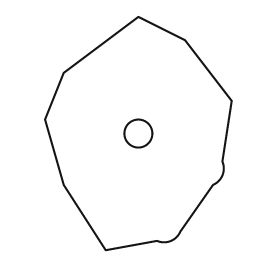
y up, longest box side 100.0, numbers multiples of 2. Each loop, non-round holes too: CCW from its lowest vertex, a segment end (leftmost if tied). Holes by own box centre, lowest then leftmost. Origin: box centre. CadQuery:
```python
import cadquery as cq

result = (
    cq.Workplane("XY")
    .moveTo(-14.0, -50.0)
    .lineTo(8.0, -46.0)
    .threePointArc((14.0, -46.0), (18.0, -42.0))
    .lineTo(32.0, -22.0)
    .threePointArc((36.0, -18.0), (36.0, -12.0))
    .lineTo(40.0, 14.0)
    .lineTo(20.0, 40.0)
    .lineTo(0.0, 50.0)
    .lineTo(-32.0, 26.0)
    .lineTo(-40.0, 6.0)
    .lineTo(-32.0, -22.0)
    .close()
    .moveTo(0.0, 0.0)
    .circle(6.0)
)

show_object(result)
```